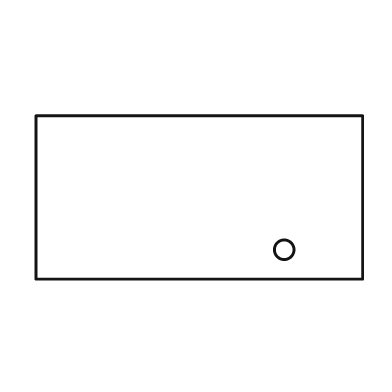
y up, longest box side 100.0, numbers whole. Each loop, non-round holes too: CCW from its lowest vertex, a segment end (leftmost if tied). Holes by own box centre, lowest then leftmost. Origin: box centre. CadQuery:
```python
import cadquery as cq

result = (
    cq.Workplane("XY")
    .moveTo(-50.0, -25.0)
    .lineTo(50.0, -25.0)
    .lineTo(50.0, 25.0)
    .lineTo(-50.0, 25.0)
    .close()
    .moveTo(26.0, -16.0)
    .circle(3.0)
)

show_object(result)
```